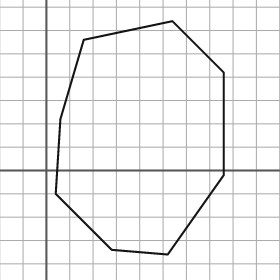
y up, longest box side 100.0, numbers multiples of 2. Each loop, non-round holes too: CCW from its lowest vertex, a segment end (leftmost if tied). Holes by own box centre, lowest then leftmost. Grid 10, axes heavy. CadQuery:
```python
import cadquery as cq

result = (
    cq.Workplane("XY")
    .moveTo(52.0, -36.0)
    .lineTo(76.0, -2.0)
    .lineTo(76.0, 42.0)
    .lineTo(54.0, 64.0)
    .lineTo(16.0, 56.0)
    .lineTo(6.0, 22.0)
    .lineTo(4.0, -10.0)
    .lineTo(28.0, -34.0)
    .close()
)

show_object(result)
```